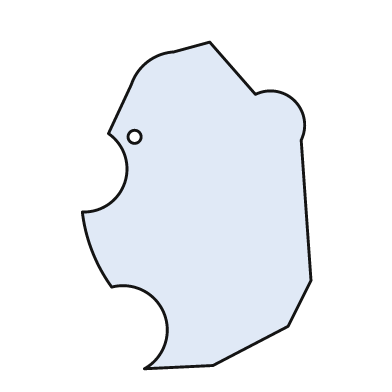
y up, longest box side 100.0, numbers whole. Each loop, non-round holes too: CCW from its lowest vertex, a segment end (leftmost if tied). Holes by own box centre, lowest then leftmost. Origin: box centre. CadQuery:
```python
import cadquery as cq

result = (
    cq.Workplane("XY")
    .moveTo(-16.0, -50.0)
    .lineTo(5.0, -49.0)
    .lineTo(28.0, -37.0)
    .lineTo(35.0, -23.0)
    .lineTo(32.0, 20.0)
    .threePointArc((30.0, 32.0), (18.0, 34.0))
    .lineTo(4.0, 50.0)
    .lineTo(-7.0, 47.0)
    .threePointArc((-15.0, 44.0), (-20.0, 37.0))
    .lineTo(-27.0, 22.0)
    .threePointArc((-22.0, 7.0), (-35.0, -2.0))
    .threePointArc((-32.0, -14.0), (-26.0, -25.0))
    .threePointArc((-10.0, -33.0), (-16.0, -50.0))
    .close()
    .moveTo(-19.0, 21.0)
    .circle(2.0)
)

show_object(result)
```